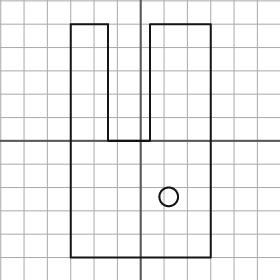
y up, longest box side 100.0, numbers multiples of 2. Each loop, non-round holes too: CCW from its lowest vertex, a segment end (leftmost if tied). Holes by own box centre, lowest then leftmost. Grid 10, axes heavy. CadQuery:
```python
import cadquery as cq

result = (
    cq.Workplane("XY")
    .moveTo(-30.0, -50.0)
    .lineTo(30.0, -50.0)
    .lineTo(30.0, 50.0)
    .lineTo(4.0, 50.0)
    .lineTo(4.0, 0.0)
    .lineTo(-14.0, 0.0)
    .lineTo(-14.0, 50.0)
    .lineTo(-30.0, 50.0)
    .close()
    .moveTo(12.0, -24.0)
    .circle(4.0)
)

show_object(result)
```